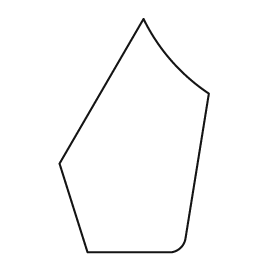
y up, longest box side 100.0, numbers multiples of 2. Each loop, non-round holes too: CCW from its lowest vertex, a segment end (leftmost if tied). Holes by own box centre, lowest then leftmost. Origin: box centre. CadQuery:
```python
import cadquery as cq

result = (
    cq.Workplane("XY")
    .moveTo(-20.0, -50.0)
    .lineTo(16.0, -50.0)
    .threePointArc((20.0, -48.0), (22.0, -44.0))
    .lineTo(32.0, 18.0)
    .threePointArc((16.0, 32.0), (4.0, 50.0))
    .lineTo(-32.0, -12.0)
    .close()
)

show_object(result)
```